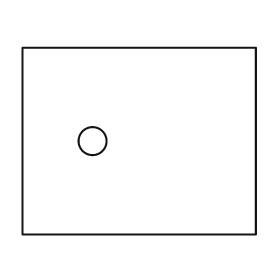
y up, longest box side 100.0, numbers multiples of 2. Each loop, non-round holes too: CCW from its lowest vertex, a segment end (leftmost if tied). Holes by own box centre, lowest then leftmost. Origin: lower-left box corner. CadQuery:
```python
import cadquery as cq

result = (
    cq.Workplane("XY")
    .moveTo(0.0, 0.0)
    .lineTo(100.0, 0.0)
    .lineTo(100.0, 80.0)
    .lineTo(0.0, 80.0)
    .close()
    .moveTo(30.0, 40.0)
    .circle(6.0)
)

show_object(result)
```